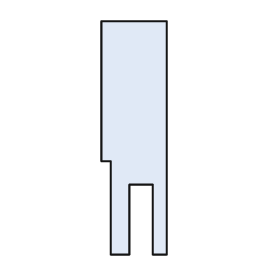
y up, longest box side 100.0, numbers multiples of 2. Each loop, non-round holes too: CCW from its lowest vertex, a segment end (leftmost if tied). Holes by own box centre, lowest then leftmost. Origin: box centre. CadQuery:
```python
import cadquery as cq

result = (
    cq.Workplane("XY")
    .moveTo(-10.0, -50.0)
    .lineTo(-2.0, -50.0)
    .lineTo(-2.0, -20.0)
    .lineTo(8.0, -20.0)
    .lineTo(8.0, -50.0)
    .lineTo(14.0, -50.0)
    .lineTo(14.0, 50.0)
    .lineTo(-14.0, 50.0)
    .lineTo(-14.0, -10.0)
    .lineTo(-10.0, -10.0)
    .close()
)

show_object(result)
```